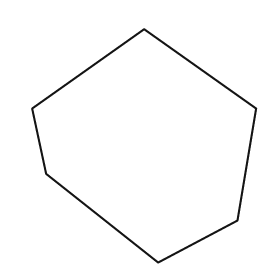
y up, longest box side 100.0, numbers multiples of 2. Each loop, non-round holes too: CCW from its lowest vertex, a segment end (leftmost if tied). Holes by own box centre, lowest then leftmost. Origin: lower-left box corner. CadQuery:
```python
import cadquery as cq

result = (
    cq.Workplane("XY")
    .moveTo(54.0, 0.0)
    .lineTo(88.0, 18.0)
    .lineTo(96.0, 66.0)
    .lineTo(48.0, 100.0)
    .lineTo(0.0, 66.0)
    .lineTo(6.0, 38.0)
    .close()
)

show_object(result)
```